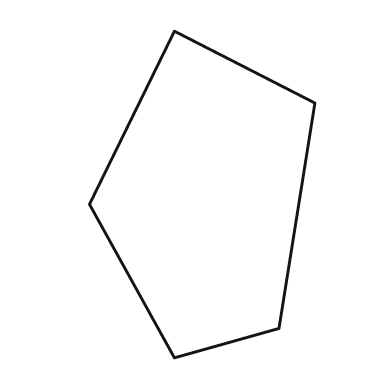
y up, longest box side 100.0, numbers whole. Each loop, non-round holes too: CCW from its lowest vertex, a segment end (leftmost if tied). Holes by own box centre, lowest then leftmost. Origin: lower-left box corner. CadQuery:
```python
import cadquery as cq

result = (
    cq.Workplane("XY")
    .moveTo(26.0, 0.0)
    .lineTo(58.0, 9.0)
    .lineTo(69.0, 78.0)
    .lineTo(26.0, 100.0)
    .lineTo(0.0, 47.0)
    .close()
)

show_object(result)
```